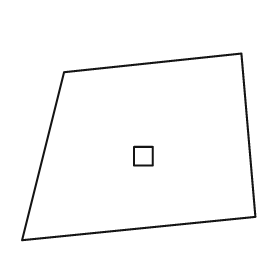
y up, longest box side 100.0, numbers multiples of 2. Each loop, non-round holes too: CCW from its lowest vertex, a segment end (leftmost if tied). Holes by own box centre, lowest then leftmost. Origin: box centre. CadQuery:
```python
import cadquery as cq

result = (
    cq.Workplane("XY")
    .moveTo(-50.0, -40.0)
    .lineTo(50.0, -30.0)
    .lineTo(44.0, 40.0)
    .lineTo(-32.0, 32.0)
    .close()
    .moveTo(-2.0, -8.0)
    .lineTo(6.0, -8.0)
    .lineTo(6.0, 0.0)
    .lineTo(-2.0, 0.0)
    .close()
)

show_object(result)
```